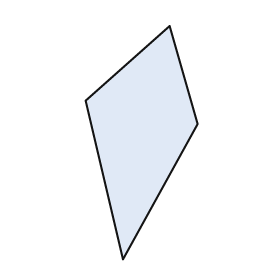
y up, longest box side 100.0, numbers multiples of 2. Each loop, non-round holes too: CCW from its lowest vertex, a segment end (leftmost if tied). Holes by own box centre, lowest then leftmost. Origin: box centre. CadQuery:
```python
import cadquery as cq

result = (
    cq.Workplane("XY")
    .moveTo(-8.0, -50.0)
    .lineTo(24.0, 8.0)
    .lineTo(12.0, 50.0)
    .lineTo(-24.0, 18.0)
    .close()
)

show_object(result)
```